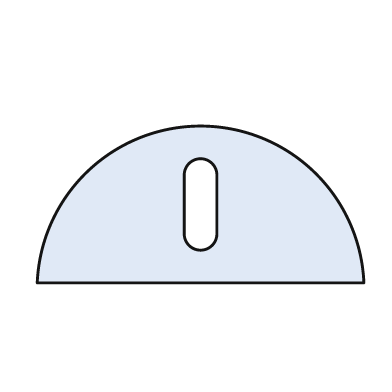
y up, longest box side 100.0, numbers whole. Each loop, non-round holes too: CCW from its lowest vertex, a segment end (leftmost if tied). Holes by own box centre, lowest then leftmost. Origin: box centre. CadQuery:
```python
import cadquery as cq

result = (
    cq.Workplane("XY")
    .moveTo(-50.0, -24.0)
    .lineTo(50.0, -24.0)
    .threePointArc((0.0, 24.0), (-50.0, -24.0))
    .close()
    .moveTo(-5.0, -9.0)
    .threePointArc((0.0, -14.0), (5.0, -9.0))
    .lineTo(5.0, 9.0)
    .threePointArc((0.0, 14.0), (-5.0, 9.0))
    .close()
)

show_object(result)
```